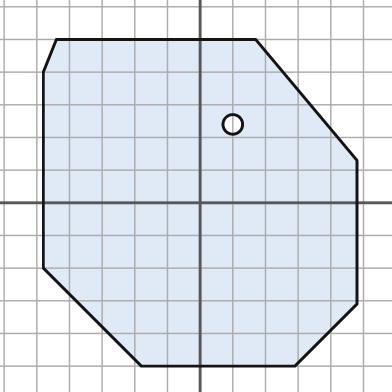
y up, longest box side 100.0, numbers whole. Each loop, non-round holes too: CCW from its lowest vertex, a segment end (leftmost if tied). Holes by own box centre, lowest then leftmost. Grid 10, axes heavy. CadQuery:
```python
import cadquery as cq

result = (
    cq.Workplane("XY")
    .moveTo(-18.0, -50.0)
    .lineTo(29.0, -50.0)
    .lineTo(48.0, -31.0)
    .lineTo(48.0, 13.0)
    .lineTo(17.0, 50.0)
    .lineTo(-44.0, 50.0)
    .lineTo(-48.0, 40.0)
    .lineTo(-48.0, -20.0)
    .close()
    .moveTo(10.0, 24.0)
    .circle(3.0)
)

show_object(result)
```